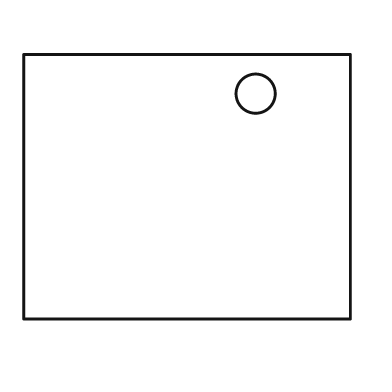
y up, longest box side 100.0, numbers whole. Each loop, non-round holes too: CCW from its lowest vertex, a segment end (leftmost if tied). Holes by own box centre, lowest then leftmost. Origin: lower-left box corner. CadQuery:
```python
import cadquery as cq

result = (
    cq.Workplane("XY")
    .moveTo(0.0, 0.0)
    .lineTo(100.0, 0.0)
    .lineTo(100.0, 81.0)
    .lineTo(0.0, 81.0)
    .close()
    .moveTo(71.0, 69.0)
    .circle(6.0)
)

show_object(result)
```